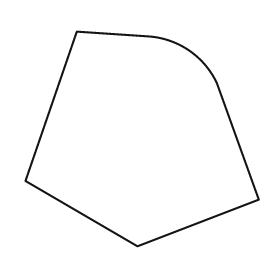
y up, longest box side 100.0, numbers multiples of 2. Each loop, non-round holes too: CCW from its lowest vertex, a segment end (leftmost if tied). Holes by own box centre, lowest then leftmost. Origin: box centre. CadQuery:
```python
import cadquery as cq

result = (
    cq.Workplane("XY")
    .moveTo(-2.0, -46.0)
    .lineTo(50.0, -26.0)
    .lineTo(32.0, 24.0)
    .threePointArc((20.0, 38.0), (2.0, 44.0))
    .lineTo(-28.0, 46.0)
    .lineTo(-50.0, -18.0)
    .close()
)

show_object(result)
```